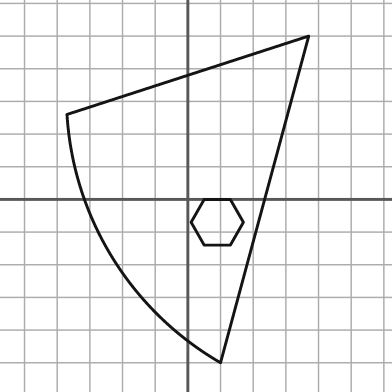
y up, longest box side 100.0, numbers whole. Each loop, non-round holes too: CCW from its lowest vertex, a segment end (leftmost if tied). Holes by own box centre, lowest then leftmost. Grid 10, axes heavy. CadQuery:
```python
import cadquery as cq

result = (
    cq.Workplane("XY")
    .moveTo(10.0, -50.0)
    .lineTo(37.0, 50.0)
    .lineTo(-37.0, 26.0)
    .threePointArc((-23.0, -18.0), (10.0, -50.0))
    .close()
    .moveTo(5.0, -14.0)
    .lineTo(13.0, -14.0)
    .lineTo(17.0, -7.0)
    .lineTo(13.0, 0.0)
    .lineTo(5.0, 0.0)
    .lineTo(1.0, -7.0)
    .close()
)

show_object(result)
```